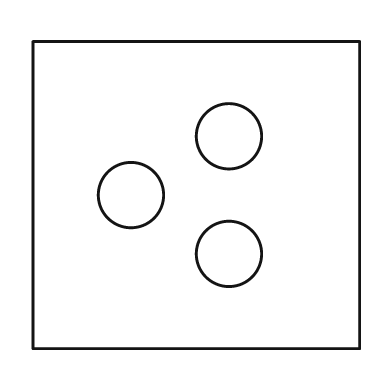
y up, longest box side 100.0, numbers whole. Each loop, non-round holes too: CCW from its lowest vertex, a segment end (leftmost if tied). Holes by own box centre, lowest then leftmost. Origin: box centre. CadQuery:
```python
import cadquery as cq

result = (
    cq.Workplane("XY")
    .moveTo(-50.0, -47.0)
    .lineTo(50.0, -47.0)
    .lineTo(50.0, 47.0)
    .lineTo(-50.0, 47.0)
    .close()
    .moveTo(10.0, -18.0)
    .circle(10.0)
    .moveTo(-20.0, 0.0)
    .circle(10.0)
    .moveTo(10.0, 18.0)
    .circle(10.0)
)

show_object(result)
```